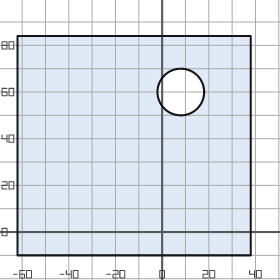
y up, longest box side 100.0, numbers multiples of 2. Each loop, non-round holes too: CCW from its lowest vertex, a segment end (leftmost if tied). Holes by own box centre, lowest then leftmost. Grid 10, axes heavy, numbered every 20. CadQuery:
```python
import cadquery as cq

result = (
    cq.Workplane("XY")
    .moveTo(-62.0, -10.0)
    .lineTo(38.0, -10.0)
    .lineTo(38.0, 84.0)
    .lineTo(-62.0, 84.0)
    .close()
    .moveTo(8.0, 60.0)
    .circle(10.0)
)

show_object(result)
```